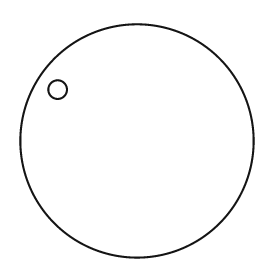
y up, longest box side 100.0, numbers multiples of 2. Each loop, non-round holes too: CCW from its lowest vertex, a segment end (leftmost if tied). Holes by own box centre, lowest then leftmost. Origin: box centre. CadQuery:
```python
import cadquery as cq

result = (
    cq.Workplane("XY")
    .moveTo(0.0, 0.0)
    .circle(50.0)
    .moveTo(-34.0, 22.0)
    .circle(4.0)
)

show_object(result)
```